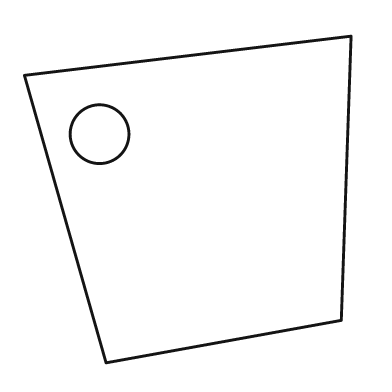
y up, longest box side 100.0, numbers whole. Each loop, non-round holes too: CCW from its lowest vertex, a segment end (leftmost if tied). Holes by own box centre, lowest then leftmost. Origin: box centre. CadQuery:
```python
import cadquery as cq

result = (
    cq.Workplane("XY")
    .moveTo(-25.0, -50.0)
    .lineTo(47.0, -37.0)
    .lineTo(50.0, 50.0)
    .lineTo(-50.0, 38.0)
    .close()
    .moveTo(-27.0, 20.0)
    .circle(9.0)
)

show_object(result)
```